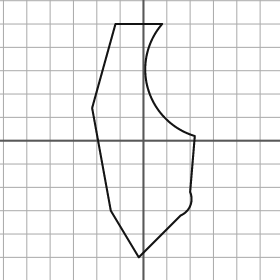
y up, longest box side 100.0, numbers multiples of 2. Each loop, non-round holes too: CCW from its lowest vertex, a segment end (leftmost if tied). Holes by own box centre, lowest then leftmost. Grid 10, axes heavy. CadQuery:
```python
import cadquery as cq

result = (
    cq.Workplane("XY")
    .moveTo(-2.0, -50.0)
    .lineTo(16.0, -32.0)
    .threePointArc((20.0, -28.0), (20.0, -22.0))
    .lineTo(22.0, 2.0)
    .threePointArc((2.0, 22.0), (8.0, 50.0))
    .lineTo(-12.0, 50.0)
    .lineTo(-22.0, 14.0)
    .lineTo(-14.0, -30.0)
    .close()
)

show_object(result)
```